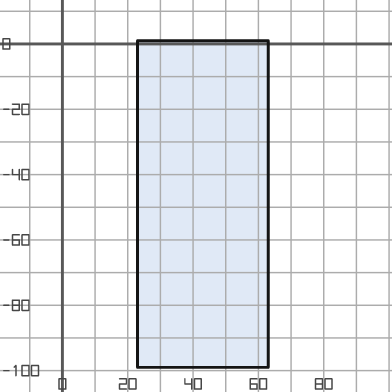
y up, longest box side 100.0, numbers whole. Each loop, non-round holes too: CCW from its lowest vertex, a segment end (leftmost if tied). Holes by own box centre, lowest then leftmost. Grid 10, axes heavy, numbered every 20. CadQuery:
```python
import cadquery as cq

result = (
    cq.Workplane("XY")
    .moveTo(23.0, -99.0)
    .lineTo(63.0, -99.0)
    .lineTo(63.0, 1.0)
    .lineTo(23.0, 1.0)
    .close()
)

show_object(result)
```